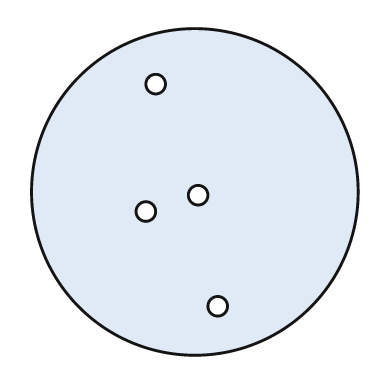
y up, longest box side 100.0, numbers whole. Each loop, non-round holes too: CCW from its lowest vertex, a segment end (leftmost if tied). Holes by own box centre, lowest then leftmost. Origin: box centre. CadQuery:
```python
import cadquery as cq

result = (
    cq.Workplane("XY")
    .moveTo(0.0, 0.0)
    .circle(50.0)
    .moveTo(7.0, -35.0)
    .circle(3.0)
    .moveTo(-15.0, -6.0)
    .circle(3.0)
    .moveTo(1.0, -1.0)
    .circle(3.0)
    .moveTo(-12.0, 33.0)
    .circle(3.0)
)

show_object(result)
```